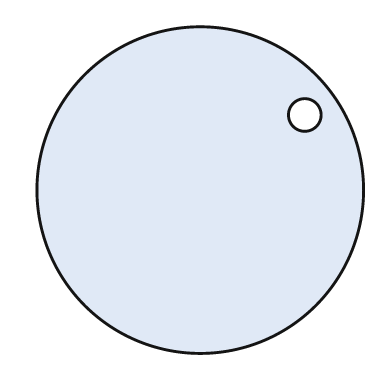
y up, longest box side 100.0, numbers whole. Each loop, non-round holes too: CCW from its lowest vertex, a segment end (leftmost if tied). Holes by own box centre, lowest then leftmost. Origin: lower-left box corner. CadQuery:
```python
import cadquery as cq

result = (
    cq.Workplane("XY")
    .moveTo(50.0, 50.0)
    .circle(50.0)
    .moveTo(82.0, 73.0)
    .circle(5.0)
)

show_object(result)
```